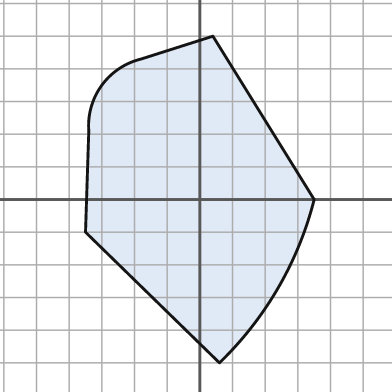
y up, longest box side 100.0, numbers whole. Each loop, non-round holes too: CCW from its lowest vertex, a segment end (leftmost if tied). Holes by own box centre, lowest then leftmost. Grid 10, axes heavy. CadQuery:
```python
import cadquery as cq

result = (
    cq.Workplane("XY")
    .moveTo(6.0, -50.0)
    .threePointArc((24.0, -27.0), (35.0, 0.0))
    .lineTo(4.0, 50.0)
    .lineTo(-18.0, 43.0)
    .threePointArc((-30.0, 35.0), (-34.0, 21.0))
    .lineTo(-35.0, -10.0)
    .close()
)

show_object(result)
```